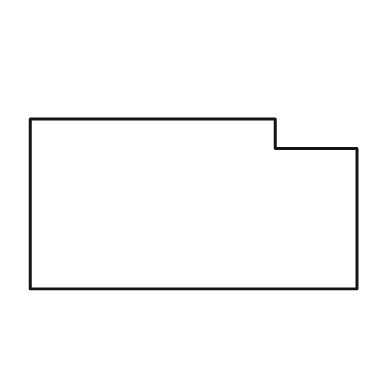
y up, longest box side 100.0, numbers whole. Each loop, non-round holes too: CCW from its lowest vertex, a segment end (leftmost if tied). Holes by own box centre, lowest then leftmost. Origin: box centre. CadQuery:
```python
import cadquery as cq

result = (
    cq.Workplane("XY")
    .moveTo(-50.0, -26.0)
    .lineTo(50.0, -26.0)
    .lineTo(50.0, 17.0)
    .lineTo(25.0, 17.0)
    .lineTo(25.0, 26.0)
    .lineTo(-50.0, 26.0)
    .close()
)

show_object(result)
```